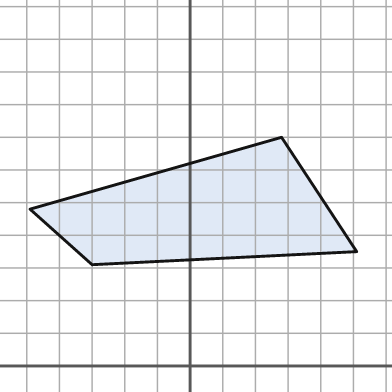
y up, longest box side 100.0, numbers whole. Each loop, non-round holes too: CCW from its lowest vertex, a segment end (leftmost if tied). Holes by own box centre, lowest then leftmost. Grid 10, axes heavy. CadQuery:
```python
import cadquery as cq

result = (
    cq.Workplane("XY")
    .moveTo(-30.0, 31.0)
    .lineTo(51.0, 35.0)
    .lineTo(28.0, 70.0)
    .lineTo(-49.0, 48.0)
    .close()
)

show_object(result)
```